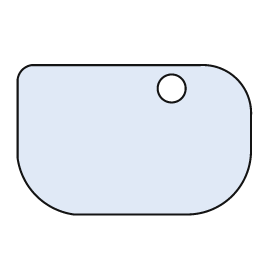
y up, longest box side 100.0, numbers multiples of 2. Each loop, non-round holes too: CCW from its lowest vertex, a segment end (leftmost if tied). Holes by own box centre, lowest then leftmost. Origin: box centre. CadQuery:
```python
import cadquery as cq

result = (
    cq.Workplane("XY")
    .moveTo(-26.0, -32.0)
    .lineTo(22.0, -32.0)
    .threePointArc((42.0, -24.0), (50.0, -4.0))
    .lineTo(50.0, 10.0)
    .threePointArc((44.0, 26.0), (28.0, 32.0))
    .lineTo(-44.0, 32.0)
    .threePointArc((-48.0, 30.0), (-50.0, 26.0))
    .lineTo(-50.0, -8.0)
    .threePointArc((-42.0, -24.0), (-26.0, -32.0))
    .close()
    .moveTo(16.0, 22.0)
    .circle(6.0)
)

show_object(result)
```